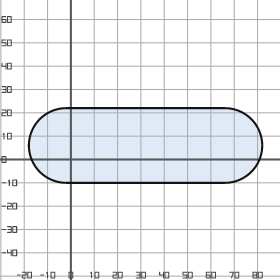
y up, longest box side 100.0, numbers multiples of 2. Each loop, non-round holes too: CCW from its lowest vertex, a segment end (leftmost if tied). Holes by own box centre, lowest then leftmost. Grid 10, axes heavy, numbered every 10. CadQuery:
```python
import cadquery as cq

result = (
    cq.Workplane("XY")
    .moveTo(-2.0, -10.0)
    .lineTo(66.0, -10.0)
    .threePointArc((82.0, 6.0), (66.0, 22.0))
    .lineTo(-2.0, 22.0)
    .threePointArc((-18.0, 6.0), (-2.0, -10.0))
    .close()
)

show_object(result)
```